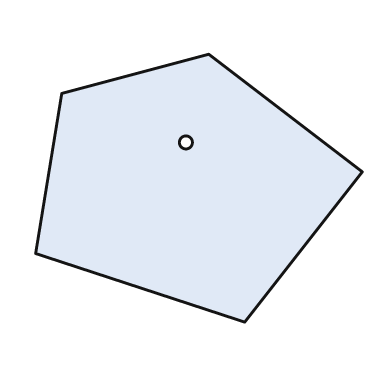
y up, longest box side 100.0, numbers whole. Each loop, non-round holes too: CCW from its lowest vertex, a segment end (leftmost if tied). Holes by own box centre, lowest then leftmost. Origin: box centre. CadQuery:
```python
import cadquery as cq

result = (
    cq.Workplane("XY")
    .moveTo(14.0, -41.0)
    .lineTo(50.0, 5.0)
    .lineTo(3.0, 41.0)
    .lineTo(-42.0, 29.0)
    .lineTo(-50.0, -20.0)
    .close()
    .moveTo(-4.0, 14.0)
    .circle(2.0)
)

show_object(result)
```